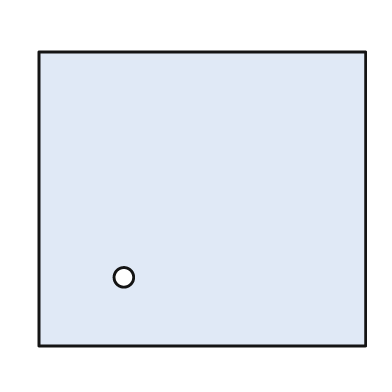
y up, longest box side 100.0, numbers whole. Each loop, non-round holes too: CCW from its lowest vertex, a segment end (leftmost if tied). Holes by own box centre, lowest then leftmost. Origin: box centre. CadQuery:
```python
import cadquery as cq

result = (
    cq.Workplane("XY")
    .moveTo(-50.0, -45.0)
    .lineTo(50.0, -45.0)
    .lineTo(50.0, 45.0)
    .lineTo(-50.0, 45.0)
    .close()
    .moveTo(-24.0, -24.0)
    .circle(3.0)
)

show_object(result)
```